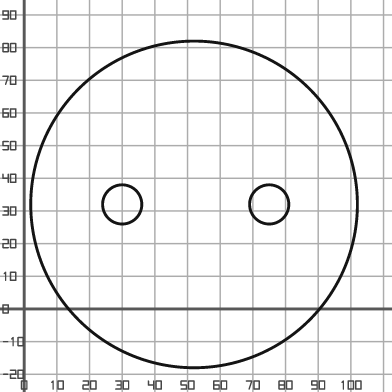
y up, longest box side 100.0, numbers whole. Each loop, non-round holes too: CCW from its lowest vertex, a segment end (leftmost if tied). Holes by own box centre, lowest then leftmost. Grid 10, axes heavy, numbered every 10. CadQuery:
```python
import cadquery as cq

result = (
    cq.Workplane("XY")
    .moveTo(52.0, 32.0)
    .circle(50.0)
    .moveTo(30.0, 32.0)
    .circle(6.0)
    .moveTo(75.0, 32.0)
    .circle(6.0)
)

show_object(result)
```